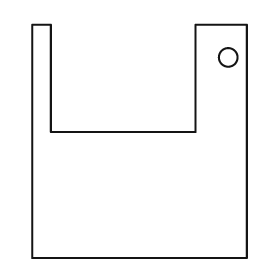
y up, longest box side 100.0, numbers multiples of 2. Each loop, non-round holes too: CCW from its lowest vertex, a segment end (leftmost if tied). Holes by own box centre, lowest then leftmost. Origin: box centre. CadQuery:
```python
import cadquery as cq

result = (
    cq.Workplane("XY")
    .moveTo(-46.0, -50.0)
    .lineTo(46.0, -50.0)
    .lineTo(46.0, 50.0)
    .lineTo(24.0, 50.0)
    .lineTo(24.0, 4.0)
    .lineTo(-38.0, 4.0)
    .lineTo(-38.0, 50.0)
    .lineTo(-46.0, 50.0)
    .close()
    .moveTo(38.0, 36.0)
    .circle(4.0)
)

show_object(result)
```